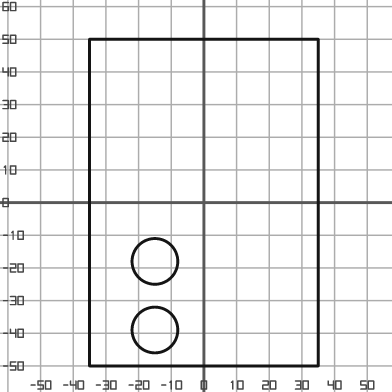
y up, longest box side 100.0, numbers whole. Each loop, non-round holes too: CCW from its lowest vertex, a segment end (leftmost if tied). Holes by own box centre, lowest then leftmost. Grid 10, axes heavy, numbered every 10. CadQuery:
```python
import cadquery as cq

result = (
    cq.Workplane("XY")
    .moveTo(-35.0, -50.0)
    .lineTo(35.0, -50.0)
    .lineTo(35.0, 50.0)
    .lineTo(-35.0, 50.0)
    .close()
    .moveTo(-15.0, -39.0)
    .circle(7.0)
    .moveTo(-15.0, -18.0)
    .circle(7.0)
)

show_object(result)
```